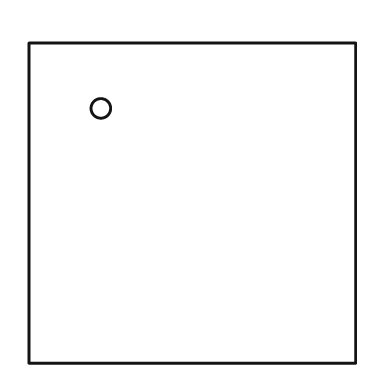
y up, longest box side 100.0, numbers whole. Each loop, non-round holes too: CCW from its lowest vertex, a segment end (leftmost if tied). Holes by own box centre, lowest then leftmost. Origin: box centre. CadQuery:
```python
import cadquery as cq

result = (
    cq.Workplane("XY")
    .moveTo(-50.0, -49.0)
    .lineTo(50.0, -49.0)
    .lineTo(50.0, 49.0)
    .lineTo(-50.0, 49.0)
    .close()
    .moveTo(-28.0, 29.0)
    .circle(3.0)
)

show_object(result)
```